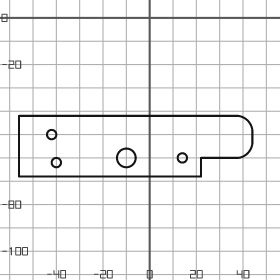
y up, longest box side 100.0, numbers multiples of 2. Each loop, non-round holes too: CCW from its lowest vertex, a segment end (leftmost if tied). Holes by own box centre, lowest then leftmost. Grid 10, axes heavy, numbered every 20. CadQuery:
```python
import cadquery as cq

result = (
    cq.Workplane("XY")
    .moveTo(-56.0, -68.0)
    .lineTo(22.0, -68.0)
    .lineTo(22.0, -60.0)
    .lineTo(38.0, -60.0)
    .threePointArc((42.0, -58.0), (44.0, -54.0))
    .lineTo(44.0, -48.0)
    .threePointArc((42.0, -44.0), (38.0, -42.0))
    .lineTo(-56.0, -42.0)
    .close()
    .moveTo(-40.0, -62.0)
    .circle(2.0)
    .moveTo(-10.0, -60.0)
    .circle(4.0)
    .moveTo(14.0, -60.0)
    .circle(2.0)
    .moveTo(-42.0, -50.0)
    .circle(2.0)
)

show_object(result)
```